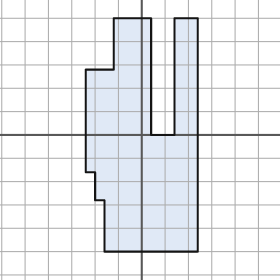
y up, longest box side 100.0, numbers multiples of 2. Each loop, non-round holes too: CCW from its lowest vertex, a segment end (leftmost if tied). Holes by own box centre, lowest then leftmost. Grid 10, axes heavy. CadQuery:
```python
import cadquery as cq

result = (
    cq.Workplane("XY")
    .moveTo(-16.0, -50.0)
    .lineTo(24.0, -50.0)
    .lineTo(24.0, 50.0)
    .lineTo(14.0, 50.0)
    .lineTo(14.0, 0.0)
    .lineTo(4.0, 0.0)
    .lineTo(4.0, 50.0)
    .lineTo(-12.0, 50.0)
    .lineTo(-12.0, 28.0)
    .lineTo(-24.0, 28.0)
    .lineTo(-24.0, -16.0)
    .lineTo(-20.0, -16.0)
    .lineTo(-20.0, -28.0)
    .lineTo(-16.0, -28.0)
    .close()
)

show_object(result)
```